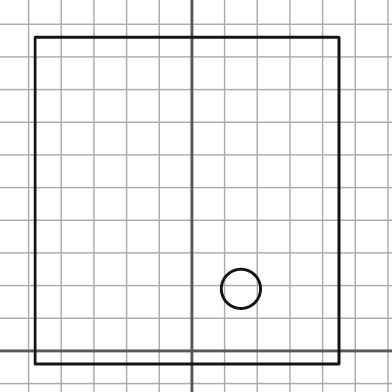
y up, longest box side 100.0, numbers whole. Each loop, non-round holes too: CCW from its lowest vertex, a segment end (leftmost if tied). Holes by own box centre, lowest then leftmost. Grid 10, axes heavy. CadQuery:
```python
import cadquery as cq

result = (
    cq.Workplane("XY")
    .moveTo(-48.0, -4.0)
    .lineTo(45.0, -4.0)
    .lineTo(45.0, 96.0)
    .lineTo(-48.0, 96.0)
    .close()
    .moveTo(15.0, 19.0)
    .circle(6.0)
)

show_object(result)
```